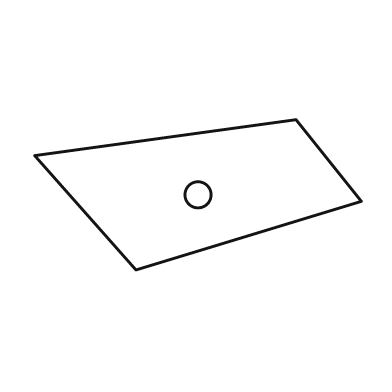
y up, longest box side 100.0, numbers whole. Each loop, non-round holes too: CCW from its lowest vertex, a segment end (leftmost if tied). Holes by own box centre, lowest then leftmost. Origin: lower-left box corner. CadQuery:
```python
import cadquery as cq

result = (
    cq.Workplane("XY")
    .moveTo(31.0, 0.0)
    .lineTo(100.0, 21.0)
    .lineTo(80.0, 46.0)
    .lineTo(0.0, 35.0)
    .close()
    .moveTo(50.0, 23.0)
    .circle(4.0)
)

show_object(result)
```